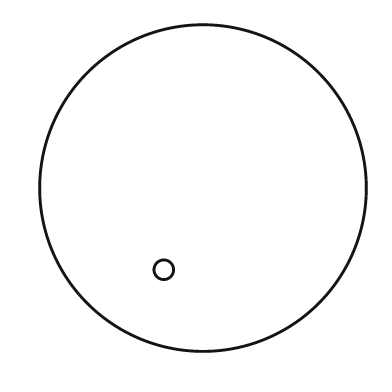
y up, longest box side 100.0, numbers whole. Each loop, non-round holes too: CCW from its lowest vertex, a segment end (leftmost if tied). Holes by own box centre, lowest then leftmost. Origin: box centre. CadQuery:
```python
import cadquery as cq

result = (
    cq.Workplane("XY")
    .moveTo(0.0, 0.0)
    .circle(50.0)
    .moveTo(-12.0, -25.0)
    .circle(3.0)
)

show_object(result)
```